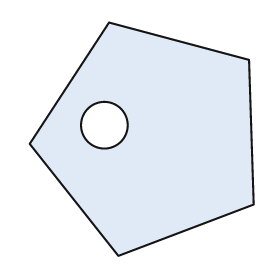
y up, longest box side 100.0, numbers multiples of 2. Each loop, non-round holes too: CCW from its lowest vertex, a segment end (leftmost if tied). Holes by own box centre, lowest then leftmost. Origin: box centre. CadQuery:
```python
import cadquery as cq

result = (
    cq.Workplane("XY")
    .moveTo(-10.0, -50.0)
    .lineTo(48.0, -28.0)
    .lineTo(46.0, 34.0)
    .lineTo(-14.0, 50.0)
    .lineTo(-48.0, -2.0)
    .close()
    .moveTo(-16.0, 6.0)
    .circle(10.0)
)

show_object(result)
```